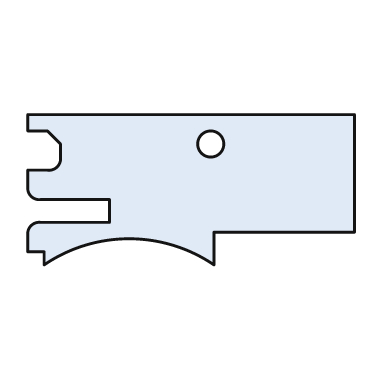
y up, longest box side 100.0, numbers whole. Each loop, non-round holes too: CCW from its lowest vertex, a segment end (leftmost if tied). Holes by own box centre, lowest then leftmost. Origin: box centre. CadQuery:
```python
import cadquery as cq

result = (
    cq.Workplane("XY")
    .moveTo(-45.0, -23.0)
    .threePointArc((-19.0, -15.0), (7.0, -23.0))
    .lineTo(7.0, -13.0)
    .lineTo(50.0, -13.0)
    .lineTo(50.0, 23.0)
    .lineTo(-50.0, 23.0)
    .lineTo(-50.0, 18.0)
    .lineTo(-44.0, 18.0)
    .lineTo(-40.0, 14.0)
    .lineTo(-40.0, 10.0)
    .threePointArc((-41.0, 7.0), (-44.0, 6.0))
    .lineTo(-50.0, 6.0)
    .lineTo(-50.0, 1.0)
    .threePointArc((-49.0, -2.0), (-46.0, -3.0))
    .lineTo(-25.0, -3.0)
    .lineTo(-25.0, -10.0)
    .lineTo(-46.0, -10.0)
    .threePointArc((-49.0, -11.0), (-50.0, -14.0))
    .lineTo(-50.0, -19.0)
    .lineTo(-45.0, -19.0)
    .close()
    .moveTo(6.0, 14.0)
    .circle(4.0)
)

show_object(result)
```